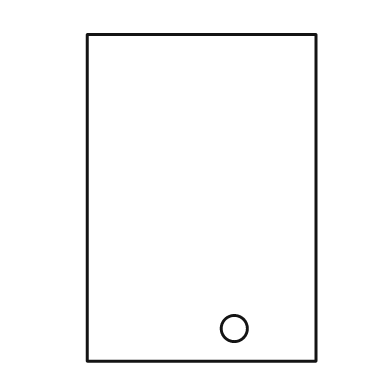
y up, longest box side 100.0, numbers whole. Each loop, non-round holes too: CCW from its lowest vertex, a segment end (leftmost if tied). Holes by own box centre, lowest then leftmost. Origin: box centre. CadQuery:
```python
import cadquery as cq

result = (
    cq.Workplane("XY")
    .moveTo(-35.0, -50.0)
    .lineTo(35.0, -50.0)
    .lineTo(35.0, 50.0)
    .lineTo(-35.0, 50.0)
    .close()
    .moveTo(10.0, -40.0)
    .circle(4.0)
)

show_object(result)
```